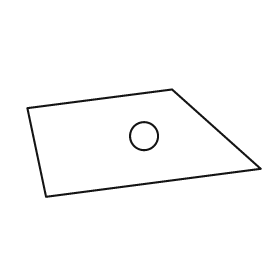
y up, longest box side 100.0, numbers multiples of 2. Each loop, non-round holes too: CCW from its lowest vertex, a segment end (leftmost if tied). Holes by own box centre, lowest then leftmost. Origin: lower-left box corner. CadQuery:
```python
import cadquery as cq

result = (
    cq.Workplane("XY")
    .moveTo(8.0, 0.0)
    .lineTo(100.0, 12.0)
    .lineTo(62.0, 46.0)
    .lineTo(0.0, 38.0)
    .close()
    .moveTo(50.0, 26.0)
    .circle(6.0)
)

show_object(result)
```